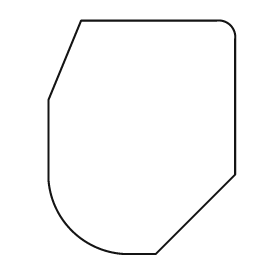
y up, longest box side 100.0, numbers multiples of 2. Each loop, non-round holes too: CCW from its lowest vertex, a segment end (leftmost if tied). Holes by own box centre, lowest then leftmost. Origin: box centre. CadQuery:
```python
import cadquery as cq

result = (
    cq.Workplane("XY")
    .moveTo(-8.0, -50.0)
    .lineTo(6.0, -50.0)
    .lineTo(40.0, -16.0)
    .lineTo(40.0, 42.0)
    .threePointArc((38.0, 48.0), (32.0, 50.0))
    .lineTo(-26.0, 50.0)
    .lineTo(-40.0, 16.0)
    .lineTo(-40.0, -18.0)
    .threePointArc((-30.0, -40.0), (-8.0, -50.0))
    .close()
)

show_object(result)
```